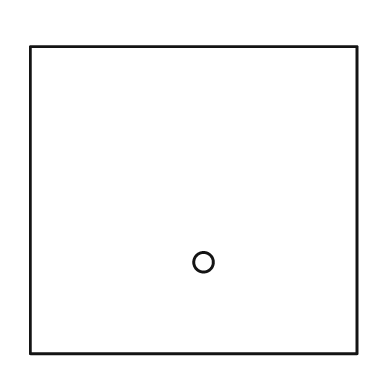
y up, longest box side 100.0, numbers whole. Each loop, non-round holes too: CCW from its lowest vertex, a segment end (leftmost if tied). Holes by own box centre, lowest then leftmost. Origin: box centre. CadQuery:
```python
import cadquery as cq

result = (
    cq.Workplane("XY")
    .moveTo(-50.0, -47.0)
    .lineTo(50.0, -47.0)
    .lineTo(50.0, 47.0)
    .lineTo(-50.0, 47.0)
    .close()
    .moveTo(3.0, -19.0)
    .circle(3.0)
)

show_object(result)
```